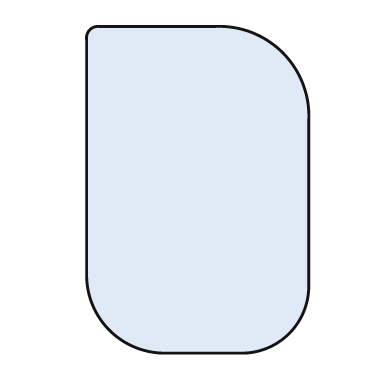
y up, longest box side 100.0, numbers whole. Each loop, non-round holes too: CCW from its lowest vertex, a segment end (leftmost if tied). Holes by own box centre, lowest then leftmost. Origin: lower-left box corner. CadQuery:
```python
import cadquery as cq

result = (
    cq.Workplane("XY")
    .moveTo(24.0, 0.0)
    .lineTo(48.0, 0.0)
    .threePointArc((62.0, 6.0), (68.0, 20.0))
    .lineTo(68.0, 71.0)
    .threePointArc((60.0, 92.0), (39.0, 100.0))
    .lineTo(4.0, 100.0)
    .threePointArc((1.0, 99.0), (0.0, 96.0))
    .lineTo(0.0, 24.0)
    .threePointArc((7.0, 7.0), (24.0, 0.0))
    .close()
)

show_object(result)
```